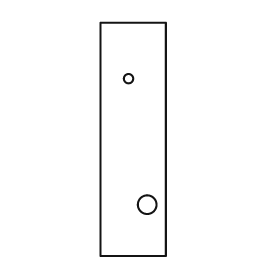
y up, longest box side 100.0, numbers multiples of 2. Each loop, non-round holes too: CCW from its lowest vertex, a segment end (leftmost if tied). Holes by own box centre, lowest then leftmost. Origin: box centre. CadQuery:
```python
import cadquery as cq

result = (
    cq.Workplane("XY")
    .moveTo(-14.0, -50.0)
    .lineTo(14.0, -50.0)
    .lineTo(14.0, 50.0)
    .lineTo(-14.0, 50.0)
    .close()
    .moveTo(6.0, -28.0)
    .circle(4.0)
    .moveTo(-2.0, 26.0)
    .circle(2.0)
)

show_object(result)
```